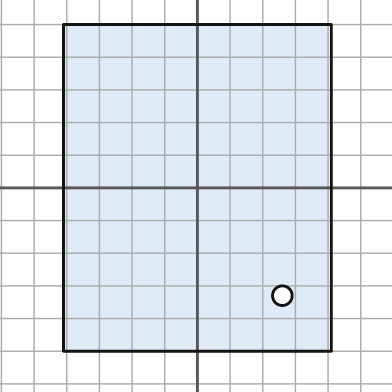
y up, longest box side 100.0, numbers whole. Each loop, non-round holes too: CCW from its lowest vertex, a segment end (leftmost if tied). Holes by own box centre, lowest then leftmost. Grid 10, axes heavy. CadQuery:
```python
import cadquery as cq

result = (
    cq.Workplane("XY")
    .moveTo(-41.0, -50.0)
    .lineTo(41.0, -50.0)
    .lineTo(41.0, 50.0)
    .lineTo(-41.0, 50.0)
    .close()
    .moveTo(26.0, -33.0)
    .circle(3.0)
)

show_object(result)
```